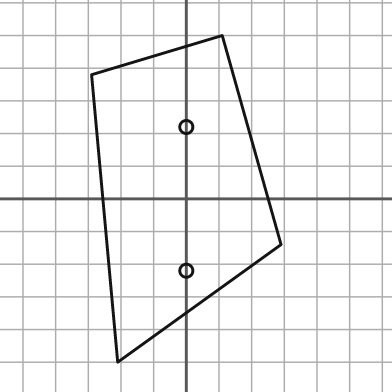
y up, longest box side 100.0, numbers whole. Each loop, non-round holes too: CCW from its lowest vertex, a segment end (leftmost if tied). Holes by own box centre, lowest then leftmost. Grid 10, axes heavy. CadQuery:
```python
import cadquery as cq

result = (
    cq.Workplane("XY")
    .moveTo(-21.0, -50.0)
    .lineTo(29.0, -14.0)
    .lineTo(11.0, 50.0)
    .lineTo(-29.0, 38.0)
    .close()
    .moveTo(0.0, -22.0)
    .circle(2.0)
    .moveTo(0.0, 22.0)
    .circle(2.0)
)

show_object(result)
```